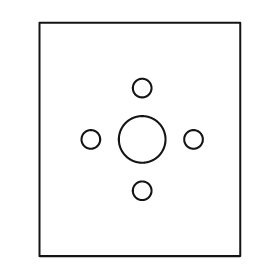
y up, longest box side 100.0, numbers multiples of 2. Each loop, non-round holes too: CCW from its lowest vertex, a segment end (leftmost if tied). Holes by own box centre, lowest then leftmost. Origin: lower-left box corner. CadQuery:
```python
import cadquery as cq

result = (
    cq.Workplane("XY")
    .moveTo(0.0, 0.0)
    .lineTo(86.0, 0.0)
    .lineTo(86.0, 100.0)
    .lineTo(0.0, 100.0)
    .close()
    .moveTo(44.0, 28.0)
    .circle(4.0)
    .moveTo(22.0, 50.0)
    .circle(4.0)
    .moveTo(44.0, 50.0)
    .circle(10.0)
    .moveTo(66.0, 50.0)
    .circle(4.0)
    .moveTo(44.0, 72.0)
    .circle(4.0)
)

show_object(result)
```